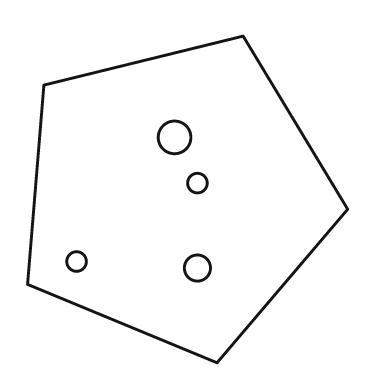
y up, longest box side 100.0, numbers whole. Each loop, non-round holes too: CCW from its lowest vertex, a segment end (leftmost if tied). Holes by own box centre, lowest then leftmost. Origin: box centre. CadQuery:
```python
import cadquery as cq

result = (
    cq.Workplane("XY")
    .moveTo(9.0, -50.0)
    .lineTo(49.0, -3.0)
    .lineTo(17.0, 50.0)
    .lineTo(-44.0, 35.0)
    .lineTo(-49.0, -26.0)
    .close()
    .moveTo(3.0, -21.0)
    .circle(4.0)
    .moveTo(-34.0, -19.0)
    .circle(3.0)
    .moveTo(3.0, 5.0)
    .circle(3.0)
    .moveTo(-4.0, 19.0)
    .circle(5.0)
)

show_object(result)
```